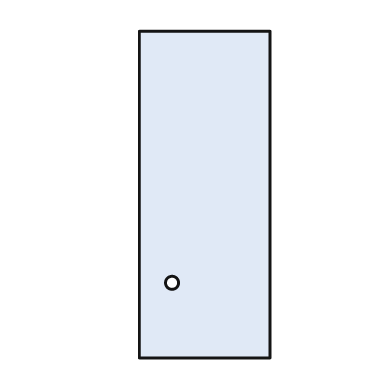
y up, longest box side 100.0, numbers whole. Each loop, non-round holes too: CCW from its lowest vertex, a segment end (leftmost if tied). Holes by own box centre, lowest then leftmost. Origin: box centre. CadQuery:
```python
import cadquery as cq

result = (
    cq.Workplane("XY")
    .moveTo(-20.0, -50.0)
    .lineTo(20.0, -50.0)
    .lineTo(20.0, 50.0)
    .lineTo(-20.0, 50.0)
    .close()
    .moveTo(-10.0, -27.0)
    .circle(2.0)
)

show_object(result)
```